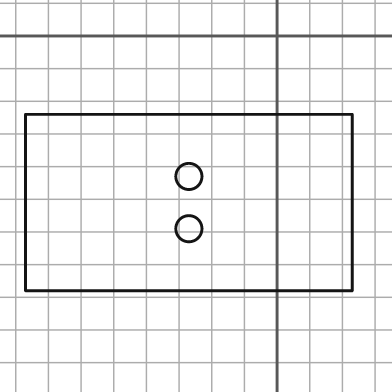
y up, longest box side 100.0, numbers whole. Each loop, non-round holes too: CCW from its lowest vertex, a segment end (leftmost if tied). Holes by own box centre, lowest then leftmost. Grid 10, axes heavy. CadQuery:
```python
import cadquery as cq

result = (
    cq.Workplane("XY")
    .moveTo(-77.0, -78.0)
    .lineTo(23.0, -78.0)
    .lineTo(23.0, -24.0)
    .lineTo(-77.0, -24.0)
    .close()
    .moveTo(-27.0, -59.0)
    .circle(4.0)
    .moveTo(-27.0, -43.0)
    .circle(4.0)
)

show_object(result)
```